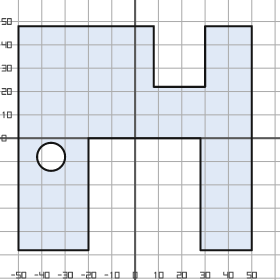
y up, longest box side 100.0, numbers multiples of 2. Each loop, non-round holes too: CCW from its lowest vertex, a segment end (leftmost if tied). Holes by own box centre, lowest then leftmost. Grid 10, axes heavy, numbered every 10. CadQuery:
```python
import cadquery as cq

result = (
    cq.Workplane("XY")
    .moveTo(-50.0, -48.0)
    .lineTo(-20.0, -48.0)
    .lineTo(-20.0, 0.0)
    .lineTo(28.0, 0.0)
    .lineTo(28.0, -48.0)
    .lineTo(50.0, -48.0)
    .lineTo(50.0, 48.0)
    .lineTo(30.0, 48.0)
    .lineTo(30.0, 22.0)
    .lineTo(8.0, 22.0)
    .lineTo(8.0, 48.0)
    .lineTo(-50.0, 48.0)
    .close()
    .moveTo(-36.0, -8.0)
    .circle(6.0)
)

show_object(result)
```